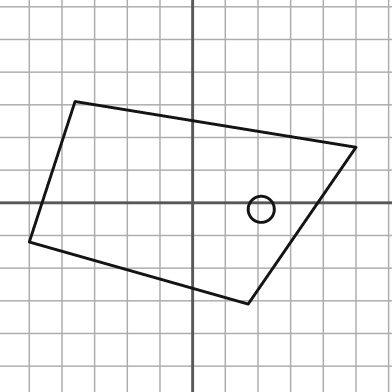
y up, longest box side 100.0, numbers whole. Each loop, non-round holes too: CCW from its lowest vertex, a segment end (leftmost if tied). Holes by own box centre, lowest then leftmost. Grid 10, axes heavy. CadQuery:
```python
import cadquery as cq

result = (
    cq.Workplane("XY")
    .moveTo(17.0, -31.0)
    .lineTo(50.0, 17.0)
    .lineTo(-36.0, 31.0)
    .lineTo(-50.0, -12.0)
    .close()
    .moveTo(21.0, -2.0)
    .circle(4.0)
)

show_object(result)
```